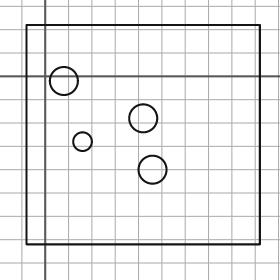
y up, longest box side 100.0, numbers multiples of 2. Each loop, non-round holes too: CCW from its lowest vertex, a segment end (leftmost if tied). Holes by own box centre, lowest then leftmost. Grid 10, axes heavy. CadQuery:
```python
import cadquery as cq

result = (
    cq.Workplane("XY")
    .moveTo(-8.0, -72.0)
    .lineTo(92.0, -72.0)
    .lineTo(92.0, 22.0)
    .lineTo(-8.0, 22.0)
    .close()
    .moveTo(46.0, -40.0)
    .circle(6.0)
    .moveTo(16.0, -28.0)
    .circle(4.0)
    .moveTo(42.0, -18.0)
    .circle(6.0)
    .moveTo(8.0, -2.0)
    .circle(6.0)
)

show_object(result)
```